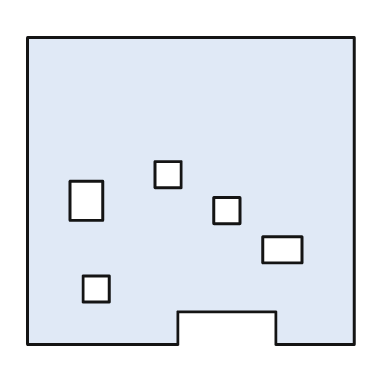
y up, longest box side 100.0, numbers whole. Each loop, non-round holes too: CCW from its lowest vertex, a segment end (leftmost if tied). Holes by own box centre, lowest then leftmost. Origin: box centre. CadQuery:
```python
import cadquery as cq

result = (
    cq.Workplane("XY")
    .moveTo(-50.0, -47.0)
    .lineTo(-4.0, -47.0)
    .lineTo(-4.0, -37.0)
    .lineTo(26.0, -37.0)
    .lineTo(26.0, -47.0)
    .lineTo(50.0, -47.0)
    .lineTo(50.0, 47.0)
    .lineTo(-50.0, 47.0)
    .close()
    .moveTo(-33.0, -34.0)
    .lineTo(-25.0, -34.0)
    .lineTo(-25.0, -26.0)
    .lineTo(-33.0, -26.0)
    .close()
    .moveTo(22.0, -22.0)
    .lineTo(34.0, -22.0)
    .lineTo(34.0, -14.0)
    .lineTo(22.0, -14.0)
    .close()
    .moveTo(7.0, -10.0)
    .lineTo(15.0, -10.0)
    .lineTo(15.0, -2.0)
    .lineTo(7.0, -2.0)
    .close()
    .moveTo(-37.0, -9.0)
    .lineTo(-27.0, -9.0)
    .lineTo(-27.0, 3.0)
    .lineTo(-37.0, 3.0)
    .close()
    .moveTo(-11.0, 1.0)
    .lineTo(-3.0, 1.0)
    .lineTo(-3.0, 9.0)
    .lineTo(-11.0, 9.0)
    .close()
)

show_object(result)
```